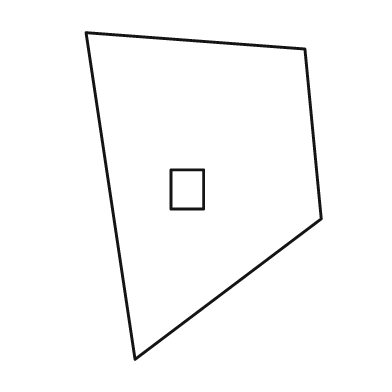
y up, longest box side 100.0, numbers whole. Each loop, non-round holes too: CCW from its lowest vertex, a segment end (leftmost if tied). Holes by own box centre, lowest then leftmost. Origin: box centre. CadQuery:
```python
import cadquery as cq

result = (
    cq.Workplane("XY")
    .moveTo(-21.0, -50.0)
    .lineTo(36.0, -7.0)
    .lineTo(31.0, 45.0)
    .lineTo(-36.0, 50.0)
    .close()
    .moveTo(-10.0, -4.0)
    .lineTo(0.0, -4.0)
    .lineTo(0.0, 8.0)
    .lineTo(-10.0, 8.0)
    .close()
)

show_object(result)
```